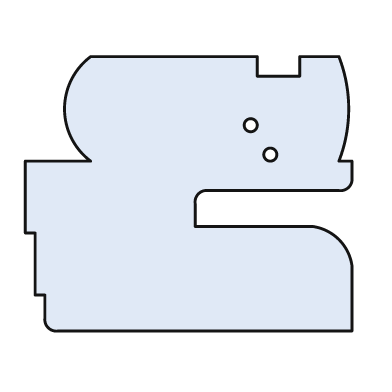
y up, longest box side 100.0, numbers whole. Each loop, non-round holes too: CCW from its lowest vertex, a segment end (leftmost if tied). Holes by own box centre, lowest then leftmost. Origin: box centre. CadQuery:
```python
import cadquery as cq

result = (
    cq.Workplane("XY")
    .moveTo(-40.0, -42.0)
    .lineTo(50.0, -42.0)
    .lineTo(50.0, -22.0)
    .threePointArc((46.0, -14.0), (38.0, -10.0))
    .lineTo(2.0, -10.0)
    .lineTo(2.0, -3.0)
    .threePointArc((3.0, 0.0), (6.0, 1.0))
    .lineTo(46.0, 1.0)
    .threePointArc((49.0, 2.0), (50.0, 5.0))
    .lineTo(50.0, 10.0)
    .lineTo(46.0, 10.0)
    .threePointArc((49.0, 26.0), (46.0, 42.0))
    .lineTo(34.0, 42.0)
    .lineTo(34.0, 36.0)
    .lineTo(21.0, 36.0)
    .lineTo(21.0, 42.0)
    .lineTo(-30.0, 42.0)
    .threePointArc((-38.0, 26.0), (-30.0, 10.0))
    .lineTo(-50.0, 10.0)
    .lineTo(-50.0, -12.0)
    .lineTo(-47.0, -12.0)
    .lineTo(-47.0, -31.0)
    .lineTo(-44.0, -31.0)
    .lineTo(-44.0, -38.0)
    .threePointArc((-43.0, -41.0), (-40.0, -42.0))
    .close()
    .moveTo(25.0, 12.0)
    .circle(2.0)
    .moveTo(19.0, 21.0)
    .circle(2.0)
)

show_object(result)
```